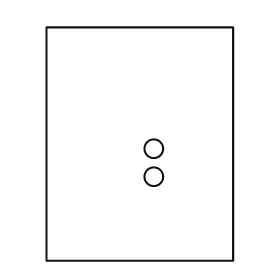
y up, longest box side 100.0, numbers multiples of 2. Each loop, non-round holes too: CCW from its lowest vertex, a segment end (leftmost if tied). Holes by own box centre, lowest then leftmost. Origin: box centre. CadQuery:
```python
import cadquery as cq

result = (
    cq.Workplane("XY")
    .moveTo(-40.0, -50.0)
    .lineTo(40.0, -50.0)
    .lineTo(40.0, 50.0)
    .lineTo(-40.0, 50.0)
    .close()
    .moveTo(6.0, -14.0)
    .circle(4.0)
    .moveTo(6.0, -2.0)
    .circle(4.0)
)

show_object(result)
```